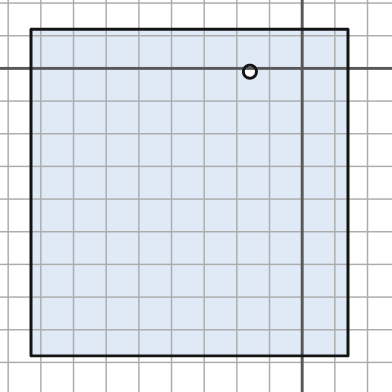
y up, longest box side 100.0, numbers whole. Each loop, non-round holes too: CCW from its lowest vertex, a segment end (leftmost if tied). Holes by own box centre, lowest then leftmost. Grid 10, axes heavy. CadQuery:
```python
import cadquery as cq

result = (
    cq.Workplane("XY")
    .moveTo(-83.0, -88.0)
    .lineTo(14.0, -88.0)
    .lineTo(14.0, 12.0)
    .lineTo(-83.0, 12.0)
    .close()
    .moveTo(-16.0, -1.0)
    .circle(2.0)
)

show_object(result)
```